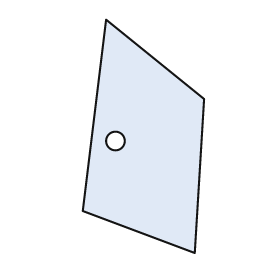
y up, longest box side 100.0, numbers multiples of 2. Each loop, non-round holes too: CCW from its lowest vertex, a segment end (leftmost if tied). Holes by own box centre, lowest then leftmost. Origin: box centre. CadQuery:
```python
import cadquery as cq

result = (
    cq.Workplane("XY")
    .moveTo(22.0, -50.0)
    .lineTo(26.0, 16.0)
    .lineTo(-16.0, 50.0)
    .lineTo(-26.0, -32.0)
    .close()
    .moveTo(-12.0, -2.0)
    .circle(4.0)
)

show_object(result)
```